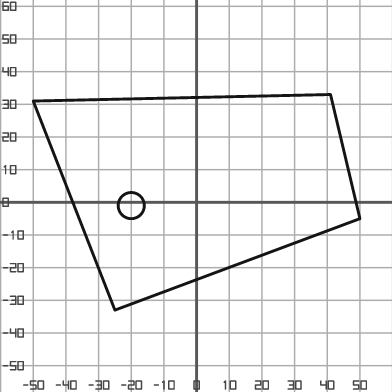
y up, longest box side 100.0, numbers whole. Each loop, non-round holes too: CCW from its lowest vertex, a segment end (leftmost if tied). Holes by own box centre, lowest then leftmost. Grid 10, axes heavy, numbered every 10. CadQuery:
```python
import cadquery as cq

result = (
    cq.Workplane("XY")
    .moveTo(-25.0, -33.0)
    .lineTo(50.0, -5.0)
    .lineTo(41.0, 33.0)
    .lineTo(-50.0, 31.0)
    .close()
    .moveTo(-20.0, -1.0)
    .circle(4.0)
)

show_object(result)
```